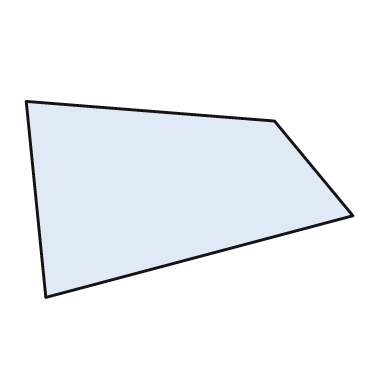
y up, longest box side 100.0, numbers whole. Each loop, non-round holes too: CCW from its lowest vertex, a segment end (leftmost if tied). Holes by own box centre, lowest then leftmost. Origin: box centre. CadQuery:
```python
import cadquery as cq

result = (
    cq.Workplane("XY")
    .moveTo(-44.0, -30.0)
    .lineTo(50.0, -5.0)
    .lineTo(26.0, 24.0)
    .lineTo(-50.0, 30.0)
    .close()
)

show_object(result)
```